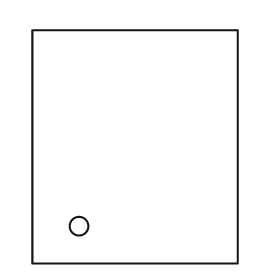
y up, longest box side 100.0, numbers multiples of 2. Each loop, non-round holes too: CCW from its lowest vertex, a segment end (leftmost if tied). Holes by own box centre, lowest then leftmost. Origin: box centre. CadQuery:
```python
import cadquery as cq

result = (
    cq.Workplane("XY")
    .moveTo(-44.0, -50.0)
    .lineTo(44.0, -50.0)
    .lineTo(44.0, 50.0)
    .lineTo(-44.0, 50.0)
    .close()
    .moveTo(-24.0, -34.0)
    .circle(4.0)
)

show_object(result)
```